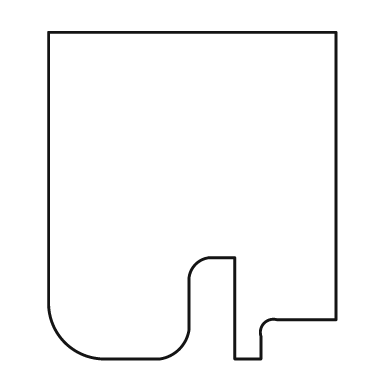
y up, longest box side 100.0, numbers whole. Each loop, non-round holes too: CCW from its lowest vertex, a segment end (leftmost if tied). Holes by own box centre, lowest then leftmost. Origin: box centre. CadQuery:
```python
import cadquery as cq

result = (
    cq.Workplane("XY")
    .moveTo(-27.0, -50.0)
    .lineTo(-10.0, -50.0)
    .threePointArc((-4.0, -47.0), (-1.0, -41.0))
    .lineTo(-1.0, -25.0)
    .threePointArc((1.0, -21.0), (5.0, -19.0))
    .lineTo(13.0, -19.0)
    .lineTo(13.0, -50.0)
    .lineTo(21.0, -50.0)
    .lineTo(21.0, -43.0)
    .threePointArc((22.0, -39.0), (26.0, -38.0))
    .lineTo(44.0, -38.0)
    .lineTo(44.0, 50.0)
    .lineTo(-44.0, 50.0)
    .lineTo(-44.0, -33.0)
    .threePointArc((-39.0, -45.0), (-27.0, -50.0))
    .close()
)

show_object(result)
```